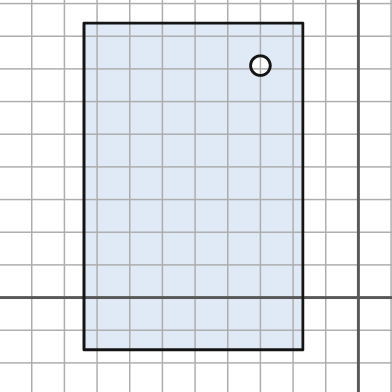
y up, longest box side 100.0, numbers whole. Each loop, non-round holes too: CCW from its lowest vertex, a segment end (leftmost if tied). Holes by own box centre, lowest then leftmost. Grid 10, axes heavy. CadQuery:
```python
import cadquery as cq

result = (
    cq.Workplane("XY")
    .moveTo(-84.0, -16.0)
    .lineTo(-17.0, -16.0)
    .lineTo(-17.0, 84.0)
    .lineTo(-84.0, 84.0)
    .close()
    .moveTo(-30.0, 71.0)
    .circle(3.0)
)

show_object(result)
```